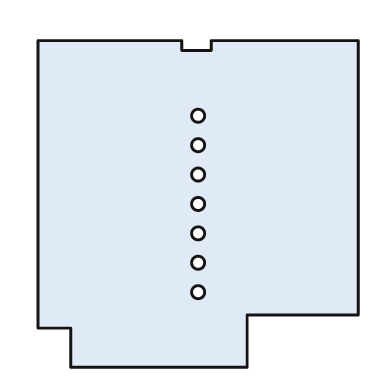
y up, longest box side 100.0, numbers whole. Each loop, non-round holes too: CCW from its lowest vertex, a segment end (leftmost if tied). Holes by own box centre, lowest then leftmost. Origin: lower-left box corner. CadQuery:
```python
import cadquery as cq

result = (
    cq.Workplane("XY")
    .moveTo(10.0, 0.0)
    .lineTo(64.0, 0.0)
    .lineTo(64.0, 16.0)
    .lineTo(98.0, 16.0)
    .lineTo(98.0, 100.0)
    .lineTo(53.0, 100.0)
    .lineTo(53.0, 97.0)
    .lineTo(44.0, 97.0)
    .lineTo(44.0, 100.0)
    .lineTo(0.0, 100.0)
    .lineTo(0.0, 12.0)
    .lineTo(10.0, 12.0)
    .close()
    .moveTo(49.0, 23.0)
    .circle(2.0)
    .moveTo(49.0, 32.0)
    .circle(2.0)
    .moveTo(49.0, 41.0)
    .circle(2.0)
    .moveTo(49.0, 50.0)
    .circle(2.0)
    .moveTo(49.0, 59.0)
    .circle(2.0)
    .moveTo(49.0, 68.0)
    .circle(2.0)
    .moveTo(49.0, 77.0)
    .circle(2.0)
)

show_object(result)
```